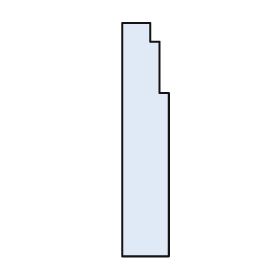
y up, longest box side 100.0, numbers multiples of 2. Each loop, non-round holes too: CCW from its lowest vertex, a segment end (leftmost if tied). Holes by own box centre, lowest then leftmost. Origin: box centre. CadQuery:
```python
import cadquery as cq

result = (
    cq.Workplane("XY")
    .moveTo(-10.0, -50.0)
    .lineTo(10.0, -50.0)
    .lineTo(10.0, 20.0)
    .lineTo(6.0, 20.0)
    .lineTo(6.0, 42.0)
    .lineTo(2.0, 42.0)
    .lineTo(2.0, 50.0)
    .lineTo(-10.0, 50.0)
    .close()
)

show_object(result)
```